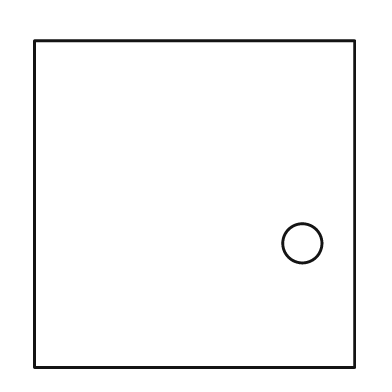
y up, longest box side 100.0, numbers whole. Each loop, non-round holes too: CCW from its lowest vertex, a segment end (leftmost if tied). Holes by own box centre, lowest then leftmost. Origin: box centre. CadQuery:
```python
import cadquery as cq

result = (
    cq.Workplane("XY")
    .moveTo(-49.0, -50.0)
    .lineTo(49.0, -50.0)
    .lineTo(49.0, 50.0)
    .lineTo(-49.0, 50.0)
    .close()
    .moveTo(33.0, -12.0)
    .circle(6.0)
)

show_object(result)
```